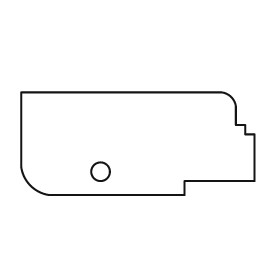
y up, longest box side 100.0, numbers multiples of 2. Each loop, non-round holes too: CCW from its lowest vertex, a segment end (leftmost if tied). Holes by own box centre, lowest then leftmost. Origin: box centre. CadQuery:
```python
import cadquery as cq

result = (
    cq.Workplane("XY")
    .moveTo(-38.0, -22.0)
    .lineTo(20.0, -22.0)
    .lineTo(20.0, -16.0)
    .lineTo(50.0, -16.0)
    .lineTo(50.0, 4.0)
    .lineTo(46.0, 4.0)
    .lineTo(46.0, 8.0)
    .lineTo(42.0, 8.0)
    .lineTo(42.0, 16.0)
    .threePointArc((40.0, 20.0), (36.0, 22.0))
    .lineTo(-50.0, 22.0)
    .lineTo(-50.0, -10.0)
    .threePointArc((-46.0, -18.0), (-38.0, -22.0))
    .close()
    .moveTo(-16.0, -12.0)
    .circle(4.0)
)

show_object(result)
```